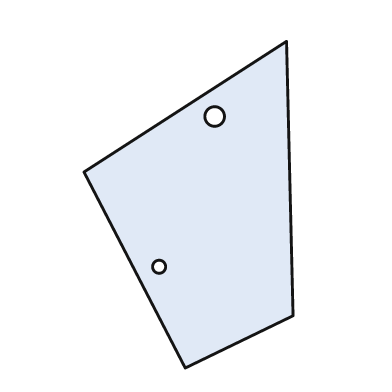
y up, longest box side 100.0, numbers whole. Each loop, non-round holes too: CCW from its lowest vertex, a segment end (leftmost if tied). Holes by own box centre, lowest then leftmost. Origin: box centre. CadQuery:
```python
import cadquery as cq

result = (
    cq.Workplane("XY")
    .moveTo(-1.0, -50.0)
    .lineTo(32.0, -34.0)
    .lineTo(30.0, 50.0)
    .lineTo(-32.0, 10.0)
    .close()
    .moveTo(-9.0, -19.0)
    .circle(2.0)
    .moveTo(8.0, 27.0)
    .circle(3.0)
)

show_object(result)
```